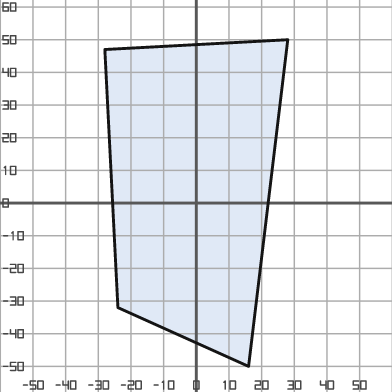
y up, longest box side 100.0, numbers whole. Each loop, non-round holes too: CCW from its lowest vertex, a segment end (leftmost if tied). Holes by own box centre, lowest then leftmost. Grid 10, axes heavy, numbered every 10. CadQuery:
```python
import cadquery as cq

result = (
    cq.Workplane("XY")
    .moveTo(16.0, -50.0)
    .lineTo(28.0, 50.0)
    .lineTo(-28.0, 47.0)
    .lineTo(-24.0, -32.0)
    .close()
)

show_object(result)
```